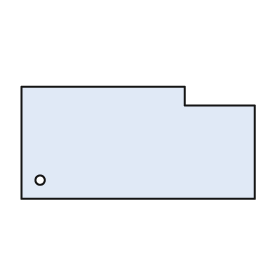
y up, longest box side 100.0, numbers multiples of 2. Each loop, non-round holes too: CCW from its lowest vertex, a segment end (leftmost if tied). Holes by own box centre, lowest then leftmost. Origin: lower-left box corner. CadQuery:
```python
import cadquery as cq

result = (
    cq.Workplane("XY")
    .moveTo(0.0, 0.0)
    .lineTo(100.0, 0.0)
    .lineTo(100.0, 40.0)
    .lineTo(70.0, 40.0)
    .lineTo(70.0, 48.0)
    .lineTo(0.0, 48.0)
    .close()
    .moveTo(8.0, 8.0)
    .circle(2.0)
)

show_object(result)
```